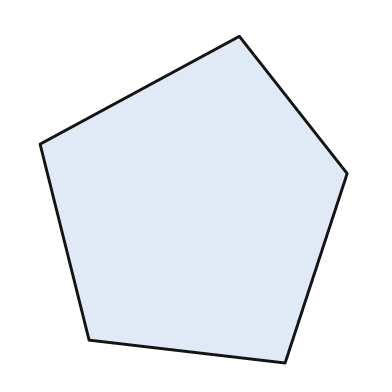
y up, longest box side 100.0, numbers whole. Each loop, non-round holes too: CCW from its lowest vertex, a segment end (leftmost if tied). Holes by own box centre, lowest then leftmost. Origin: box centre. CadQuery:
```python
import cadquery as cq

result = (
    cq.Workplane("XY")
    .moveTo(28.0, -50.0)
    .lineTo(47.0, 8.0)
    .lineTo(14.0, 50.0)
    .lineTo(-47.0, 17.0)
    .lineTo(-32.0, -43.0)
    .close()
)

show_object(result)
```